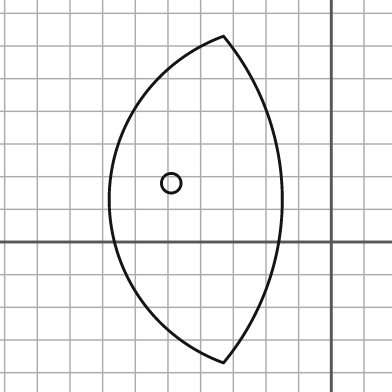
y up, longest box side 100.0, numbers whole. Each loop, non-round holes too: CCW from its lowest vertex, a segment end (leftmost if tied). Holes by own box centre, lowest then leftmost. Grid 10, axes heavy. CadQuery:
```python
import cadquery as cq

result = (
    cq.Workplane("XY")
    .moveTo(-33.0, -37.0)
    .threePointArc((-15.0, 13.0), (-33.0, 63.0))
    .threePointArc((-68.0, 13.0), (-33.0, -37.0))
    .close()
    .moveTo(-49.0, 18.0)
    .circle(3.0)
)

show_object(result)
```